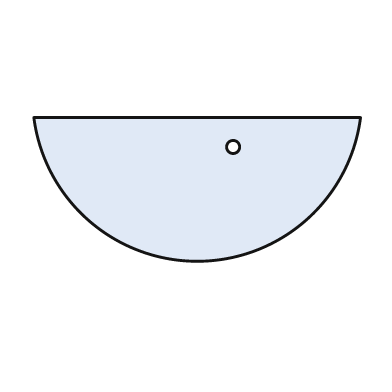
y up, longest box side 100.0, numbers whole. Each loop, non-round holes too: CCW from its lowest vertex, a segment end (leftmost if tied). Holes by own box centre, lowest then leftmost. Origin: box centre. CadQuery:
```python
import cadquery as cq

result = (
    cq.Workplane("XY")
    .moveTo(-50.0, 22.0)
    .threePointArc((0.0, -22.0), (50.0, 22.0))
    .close()
    .moveTo(11.0, 13.0)
    .circle(2.0)
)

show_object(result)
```